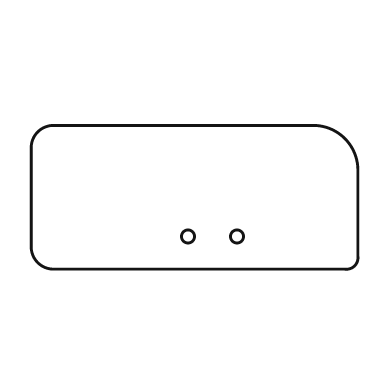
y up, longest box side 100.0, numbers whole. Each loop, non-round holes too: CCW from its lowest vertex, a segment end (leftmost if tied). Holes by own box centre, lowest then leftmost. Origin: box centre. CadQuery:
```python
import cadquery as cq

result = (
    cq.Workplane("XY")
    .moveTo(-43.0, -22.0)
    .lineTo(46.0, -22.0)
    .threePointArc((49.0, -21.0), (50.0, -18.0))
    .lineTo(50.0, 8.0)
    .threePointArc((46.0, 18.0), (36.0, 22.0))
    .lineTo(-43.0, 22.0)
    .threePointArc((-48.0, 20.0), (-50.0, 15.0))
    .lineTo(-50.0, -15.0)
    .threePointArc((-48.0, -20.0), (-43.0, -22.0))
    .close()
    .moveTo(-2.0, -12.0)
    .circle(2.0)
    .moveTo(13.0, -12.0)
    .circle(2.0)
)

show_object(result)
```